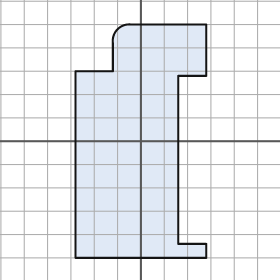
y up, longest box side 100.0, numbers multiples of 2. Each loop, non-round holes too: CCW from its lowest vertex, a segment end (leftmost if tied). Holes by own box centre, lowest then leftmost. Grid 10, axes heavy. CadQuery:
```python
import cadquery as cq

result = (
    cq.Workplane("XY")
    .moveTo(-28.0, -50.0)
    .lineTo(28.0, -50.0)
    .lineTo(28.0, -44.0)
    .lineTo(16.0, -44.0)
    .lineTo(16.0, 28.0)
    .lineTo(28.0, 28.0)
    .lineTo(28.0, 50.0)
    .lineTo(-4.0, 50.0)
    .threePointArc((-10.0, 48.0), (-12.0, 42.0))
    .lineTo(-12.0, 30.0)
    .lineTo(-28.0, 30.0)
    .close()
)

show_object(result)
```